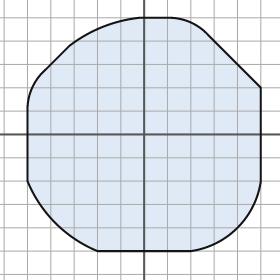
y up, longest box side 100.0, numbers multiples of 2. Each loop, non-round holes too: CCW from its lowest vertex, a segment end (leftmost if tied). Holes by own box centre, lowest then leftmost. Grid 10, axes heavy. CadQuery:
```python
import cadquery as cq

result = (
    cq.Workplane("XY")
    .moveTo(-20.0, -50.0)
    .lineTo(20.0, -50.0)
    .threePointArc((40.0, -40.0), (50.0, -20.0))
    .lineTo(50.0, 20.0)
    .lineTo(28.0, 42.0)
    .threePointArc((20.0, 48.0), (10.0, 50.0))
    .lineTo(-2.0, 50.0)
    .threePointArc((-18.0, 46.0), (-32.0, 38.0))
    .lineTo(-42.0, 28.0)
    .threePointArc((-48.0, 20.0), (-50.0, 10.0))
    .lineTo(-50.0, -20.0)
    .threePointArc((-38.0, -38.0), (-20.0, -50.0))
    .close()
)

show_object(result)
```